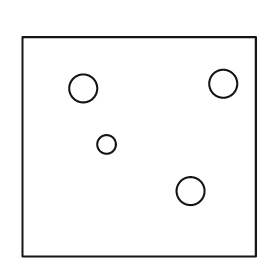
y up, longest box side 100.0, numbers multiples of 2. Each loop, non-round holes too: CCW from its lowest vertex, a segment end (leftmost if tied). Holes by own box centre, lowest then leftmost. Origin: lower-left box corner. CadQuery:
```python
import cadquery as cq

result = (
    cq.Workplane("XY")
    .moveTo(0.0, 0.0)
    .lineTo(100.0, 0.0)
    .lineTo(100.0, 94.0)
    .lineTo(0.0, 94.0)
    .close()
    .moveTo(72.0, 28.0)
    .circle(6.0)
    .moveTo(36.0, 48.0)
    .circle(4.0)
    .moveTo(26.0, 72.0)
    .circle(6.0)
    .moveTo(86.0, 74.0)
    .circle(6.0)
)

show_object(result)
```